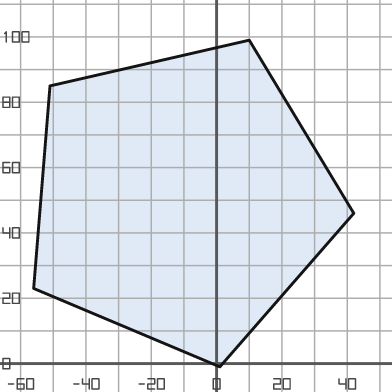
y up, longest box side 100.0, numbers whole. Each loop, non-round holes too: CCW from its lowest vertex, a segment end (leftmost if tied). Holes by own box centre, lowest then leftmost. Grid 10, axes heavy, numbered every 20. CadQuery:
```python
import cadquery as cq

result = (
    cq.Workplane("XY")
    .moveTo(1.0, -1.0)
    .lineTo(42.0, 46.0)
    .lineTo(10.0, 99.0)
    .lineTo(-51.0, 85.0)
    .lineTo(-56.0, 23.0)
    .close()
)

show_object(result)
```